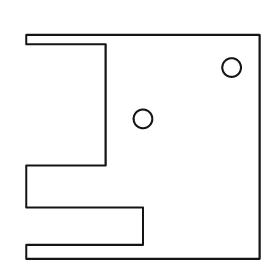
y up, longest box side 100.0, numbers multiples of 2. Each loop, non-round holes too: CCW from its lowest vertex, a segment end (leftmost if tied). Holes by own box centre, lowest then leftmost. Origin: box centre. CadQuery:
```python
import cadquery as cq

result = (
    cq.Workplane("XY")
    .moveTo(-50.0, -48.0)
    .lineTo(50.0, -48.0)
    .lineTo(50.0, 48.0)
    .lineTo(-50.0, 48.0)
    .lineTo(-50.0, 44.0)
    .lineTo(-16.0, 44.0)
    .lineTo(-16.0, -8.0)
    .lineTo(-50.0, -8.0)
    .lineTo(-50.0, -26.0)
    .lineTo(0.0, -26.0)
    .lineTo(0.0, -42.0)
    .lineTo(-50.0, -42.0)
    .close()
    .moveTo(0.0, 12.0)
    .circle(4.0)
    .moveTo(38.0, 34.0)
    .circle(4.0)
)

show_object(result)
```